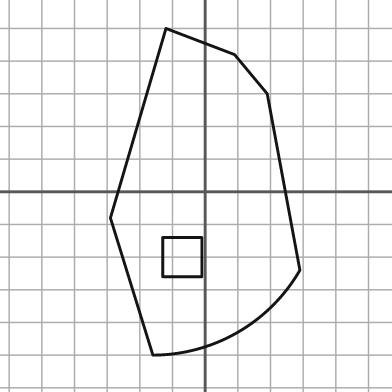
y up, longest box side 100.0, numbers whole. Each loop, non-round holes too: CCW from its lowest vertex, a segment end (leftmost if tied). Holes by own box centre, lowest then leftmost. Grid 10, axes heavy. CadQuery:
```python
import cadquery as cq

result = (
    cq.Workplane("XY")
    .moveTo(-16.0, -50.0)
    .threePointArc((10.0, -43.0), (29.0, -24.0))
    .lineTo(19.0, 30.0)
    .lineTo(9.0, 42.0)
    .lineTo(-12.0, 50.0)
    .lineTo(-29.0, -8.0)
    .close()
    .moveTo(-13.0, -26.0)
    .lineTo(-1.0, -26.0)
    .lineTo(-1.0, -14.0)
    .lineTo(-13.0, -14.0)
    .close()
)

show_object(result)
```